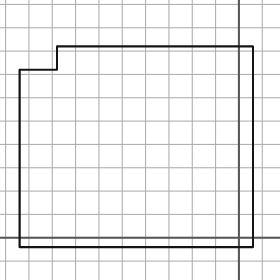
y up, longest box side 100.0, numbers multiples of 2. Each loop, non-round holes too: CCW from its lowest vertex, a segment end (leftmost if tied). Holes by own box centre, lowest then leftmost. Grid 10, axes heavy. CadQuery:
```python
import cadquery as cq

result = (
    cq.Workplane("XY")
    .moveTo(-94.0, -4.0)
    .lineTo(6.0, -4.0)
    .lineTo(6.0, 82.0)
    .lineTo(-78.0, 82.0)
    .lineTo(-78.0, 72.0)
    .lineTo(-94.0, 72.0)
    .close()
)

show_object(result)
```